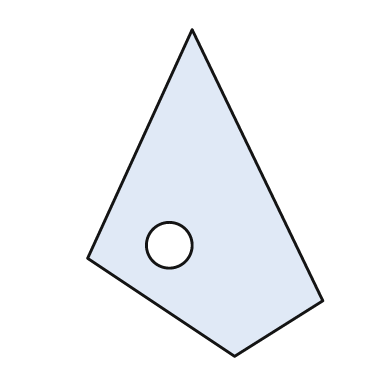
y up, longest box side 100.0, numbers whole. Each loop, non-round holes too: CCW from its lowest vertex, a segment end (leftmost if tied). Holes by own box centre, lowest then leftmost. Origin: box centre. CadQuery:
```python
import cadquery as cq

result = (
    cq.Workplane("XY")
    .moveTo(9.0, -50.0)
    .lineTo(36.0, -33.0)
    .lineTo(-4.0, 50.0)
    .lineTo(-36.0, -20.0)
    .close()
    .moveTo(-11.0, -16.0)
    .circle(7.0)
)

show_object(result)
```